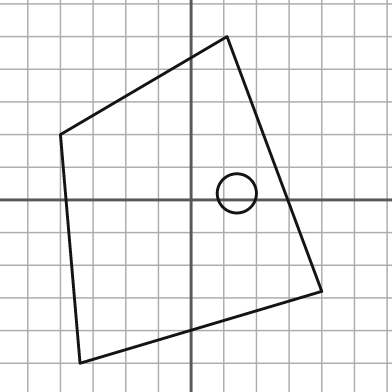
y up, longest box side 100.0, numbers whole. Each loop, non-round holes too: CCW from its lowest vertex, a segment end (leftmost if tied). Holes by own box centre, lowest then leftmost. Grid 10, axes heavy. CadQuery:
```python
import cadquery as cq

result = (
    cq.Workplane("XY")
    .moveTo(-34.0, -50.0)
    .lineTo(40.0, -28.0)
    .lineTo(11.0, 50.0)
    .lineTo(-40.0, 20.0)
    .close()
    .moveTo(14.0, 2.0)
    .circle(6.0)
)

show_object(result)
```